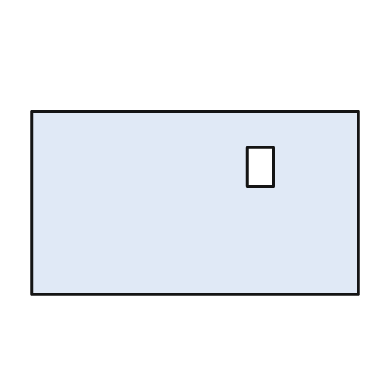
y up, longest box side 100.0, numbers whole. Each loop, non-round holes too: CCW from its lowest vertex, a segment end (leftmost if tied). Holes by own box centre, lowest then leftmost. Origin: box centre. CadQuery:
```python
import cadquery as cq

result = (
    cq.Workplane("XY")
    .moveTo(-50.0, -28.0)
    .lineTo(50.0, -28.0)
    .lineTo(50.0, 28.0)
    .lineTo(-50.0, 28.0)
    .close()
    .moveTo(16.0, 5.0)
    .lineTo(24.0, 5.0)
    .lineTo(24.0, 17.0)
    .lineTo(16.0, 17.0)
    .close()
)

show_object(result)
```